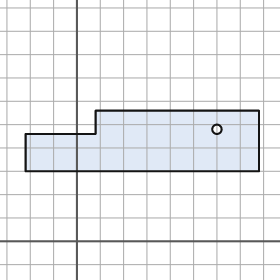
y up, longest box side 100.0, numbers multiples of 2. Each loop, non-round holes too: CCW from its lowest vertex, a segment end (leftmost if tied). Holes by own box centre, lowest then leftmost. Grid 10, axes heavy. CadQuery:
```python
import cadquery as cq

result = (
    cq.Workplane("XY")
    .moveTo(-22.0, 30.0)
    .lineTo(78.0, 30.0)
    .lineTo(78.0, 56.0)
    .lineTo(8.0, 56.0)
    .lineTo(8.0, 46.0)
    .lineTo(-22.0, 46.0)
    .close()
    .moveTo(60.0, 48.0)
    .circle(2.0)
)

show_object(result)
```